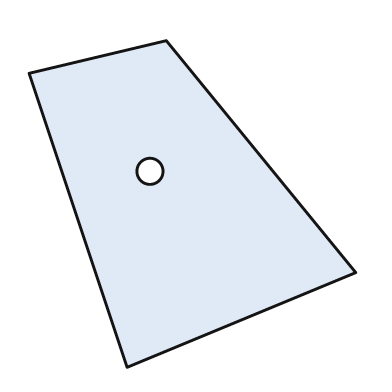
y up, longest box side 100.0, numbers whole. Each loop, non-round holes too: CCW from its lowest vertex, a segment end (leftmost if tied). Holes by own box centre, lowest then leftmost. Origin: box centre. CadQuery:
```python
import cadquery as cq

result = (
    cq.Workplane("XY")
    .moveTo(-20.0, -50.0)
    .lineTo(50.0, -21.0)
    .lineTo(-8.0, 50.0)
    .lineTo(-50.0, 40.0)
    .close()
    .moveTo(-13.0, 10.0)
    .circle(4.0)
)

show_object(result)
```